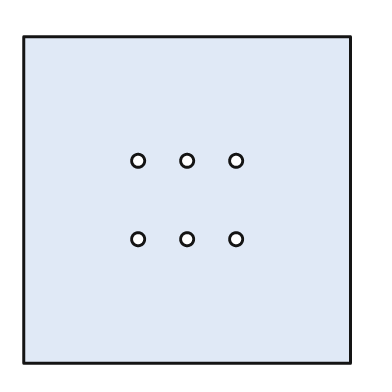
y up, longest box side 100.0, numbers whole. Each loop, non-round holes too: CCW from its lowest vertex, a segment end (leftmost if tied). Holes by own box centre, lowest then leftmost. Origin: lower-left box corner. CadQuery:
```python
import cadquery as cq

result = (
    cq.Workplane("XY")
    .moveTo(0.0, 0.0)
    .lineTo(100.0, 0.0)
    .lineTo(100.0, 100.0)
    .lineTo(0.0, 100.0)
    .close()
    .moveTo(35.0, 38.0)
    .circle(2.0)
    .moveTo(50.0, 38.0)
    .circle(2.0)
    .moveTo(65.0, 38.0)
    .circle(2.0)
    .moveTo(35.0, 62.0)
    .circle(2.0)
    .moveTo(50.0, 62.0)
    .circle(2.0)
    .moveTo(65.0, 62.0)
    .circle(2.0)
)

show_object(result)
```